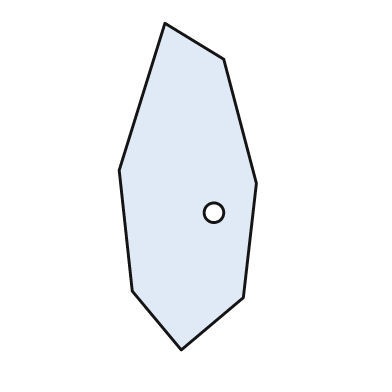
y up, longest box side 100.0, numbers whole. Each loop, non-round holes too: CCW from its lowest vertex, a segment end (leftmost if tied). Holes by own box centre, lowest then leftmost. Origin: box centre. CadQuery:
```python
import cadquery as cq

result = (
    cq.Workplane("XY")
    .moveTo(-2.0, -50.0)
    .lineTo(17.0, -34.0)
    .lineTo(21.0, 1.0)
    .lineTo(11.0, 39.0)
    .lineTo(-7.0, 50.0)
    .lineTo(-21.0, 5.0)
    .lineTo(-17.0, -32.0)
    .close()
    .moveTo(8.0, -8.0)
    .circle(3.0)
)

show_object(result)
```